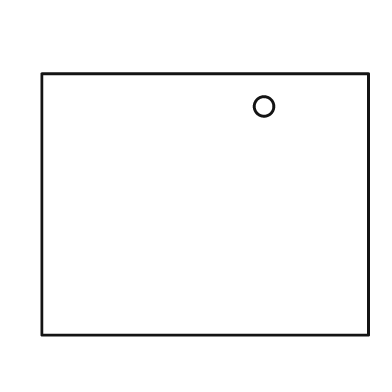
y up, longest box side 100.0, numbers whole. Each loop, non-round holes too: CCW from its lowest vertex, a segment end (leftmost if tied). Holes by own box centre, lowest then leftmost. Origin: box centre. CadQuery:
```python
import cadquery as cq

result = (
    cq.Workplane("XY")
    .moveTo(-50.0, -40.0)
    .lineTo(50.0, -40.0)
    .lineTo(50.0, 40.0)
    .lineTo(-50.0, 40.0)
    .close()
    .moveTo(18.0, 30.0)
    .circle(3.0)
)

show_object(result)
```